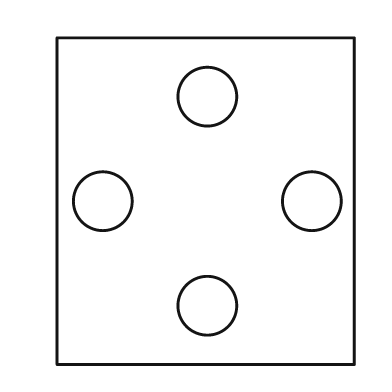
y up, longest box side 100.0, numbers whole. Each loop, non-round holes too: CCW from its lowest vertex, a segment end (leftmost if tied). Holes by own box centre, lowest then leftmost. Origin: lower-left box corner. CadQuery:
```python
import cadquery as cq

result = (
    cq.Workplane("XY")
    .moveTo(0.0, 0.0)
    .lineTo(91.0, 0.0)
    .lineTo(91.0, 100.0)
    .lineTo(0.0, 100.0)
    .close()
    .moveTo(46.0, 18.0)
    .circle(9.0)
    .moveTo(14.0, 50.0)
    .circle(9.0)
    .moveTo(78.0, 50.0)
    .circle(9.0)
    .moveTo(46.0, 82.0)
    .circle(9.0)
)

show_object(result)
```